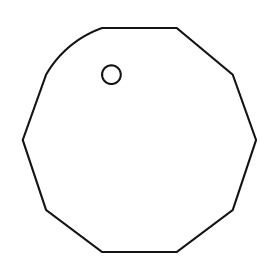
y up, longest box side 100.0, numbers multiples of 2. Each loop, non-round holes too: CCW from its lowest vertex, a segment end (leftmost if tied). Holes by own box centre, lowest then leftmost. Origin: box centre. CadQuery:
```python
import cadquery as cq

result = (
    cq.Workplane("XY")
    .moveTo(-16.0, -48.0)
    .lineTo(16.0, -48.0)
    .lineTo(40.0, -30.0)
    .lineTo(50.0, 0.0)
    .lineTo(40.0, 28.0)
    .lineTo(16.0, 48.0)
    .lineTo(-16.0, 48.0)
    .threePointArc((-30.0, 40.0), (-40.0, 28.0))
    .lineTo(-50.0, 0.0)
    .lineTo(-40.0, -30.0)
    .close()
    .moveTo(-12.0, 28.0)
    .circle(4.0)
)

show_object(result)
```